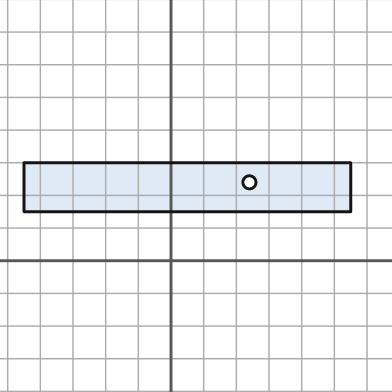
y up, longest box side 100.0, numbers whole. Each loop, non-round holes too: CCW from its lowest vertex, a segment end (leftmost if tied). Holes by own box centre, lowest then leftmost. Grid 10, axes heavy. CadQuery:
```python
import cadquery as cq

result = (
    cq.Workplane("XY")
    .moveTo(-45.0, 15.0)
    .lineTo(55.0, 15.0)
    .lineTo(55.0, 30.0)
    .lineTo(-45.0, 30.0)
    .close()
    .moveTo(24.0, 24.0)
    .circle(2.0)
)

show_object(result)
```